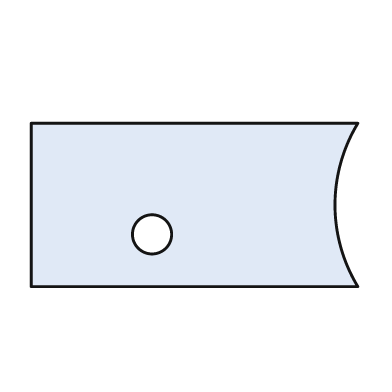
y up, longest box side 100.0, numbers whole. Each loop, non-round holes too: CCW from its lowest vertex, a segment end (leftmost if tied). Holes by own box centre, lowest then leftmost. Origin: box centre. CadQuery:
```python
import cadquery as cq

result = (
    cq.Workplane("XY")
    .moveTo(-50.0, -25.0)
    .lineTo(50.0, -25.0)
    .threePointArc((43.0, 0.0), (50.0, 25.0))
    .lineTo(-50.0, 25.0)
    .close()
    .moveTo(-13.0, -9.0)
    .circle(6.0)
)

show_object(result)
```